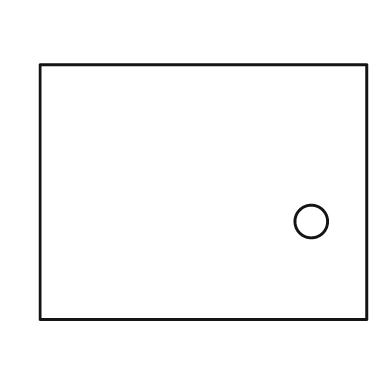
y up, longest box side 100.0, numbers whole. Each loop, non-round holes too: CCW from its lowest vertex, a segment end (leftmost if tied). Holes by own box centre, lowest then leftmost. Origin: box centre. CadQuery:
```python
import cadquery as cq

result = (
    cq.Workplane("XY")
    .moveTo(-50.0, -39.0)
    .lineTo(50.0, -39.0)
    .lineTo(50.0, 39.0)
    .lineTo(-50.0, 39.0)
    .close()
    .moveTo(33.0, -9.0)
    .circle(5.0)
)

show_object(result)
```